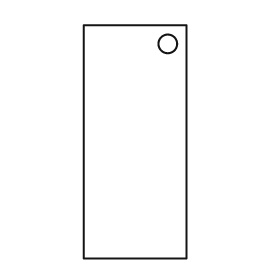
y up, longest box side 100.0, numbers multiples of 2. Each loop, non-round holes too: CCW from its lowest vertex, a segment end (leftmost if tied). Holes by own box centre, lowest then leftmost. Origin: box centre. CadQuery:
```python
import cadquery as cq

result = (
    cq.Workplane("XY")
    .moveTo(-22.0, -50.0)
    .lineTo(22.0, -50.0)
    .lineTo(22.0, 50.0)
    .lineTo(-22.0, 50.0)
    .close()
    .moveTo(14.0, 42.0)
    .circle(4.0)
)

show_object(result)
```